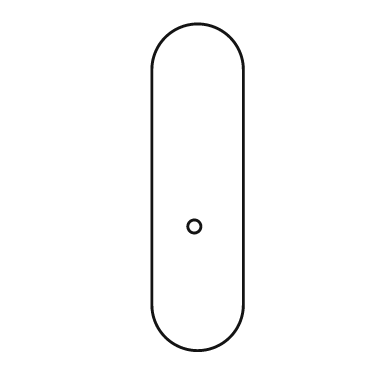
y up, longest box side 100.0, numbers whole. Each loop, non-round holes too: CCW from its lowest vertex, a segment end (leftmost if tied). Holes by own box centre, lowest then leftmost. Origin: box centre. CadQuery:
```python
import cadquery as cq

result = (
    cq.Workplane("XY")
    .moveTo(-14.0, -36.0)
    .threePointArc((0.0, -50.0), (14.0, -36.0))
    .lineTo(14.0, 36.0)
    .threePointArc((0.0, 50.0), (-14.0, 36.0))
    .close()
    .moveTo(-1.0, -12.0)
    .circle(2.0)
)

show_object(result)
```